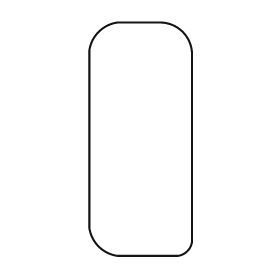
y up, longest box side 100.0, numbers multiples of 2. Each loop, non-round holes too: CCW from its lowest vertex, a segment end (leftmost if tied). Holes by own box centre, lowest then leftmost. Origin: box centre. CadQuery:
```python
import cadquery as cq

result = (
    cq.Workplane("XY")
    .moveTo(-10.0, -50.0)
    .lineTo(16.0, -50.0)
    .threePointArc((20.0, -48.0), (22.0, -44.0))
    .lineTo(22.0, 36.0)
    .threePointArc((18.0, 46.0), (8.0, 50.0))
    .lineTo(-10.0, 50.0)
    .threePointArc((-18.0, 46.0), (-22.0, 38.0))
    .lineTo(-22.0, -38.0)
    .threePointArc((-18.0, -46.0), (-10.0, -50.0))
    .close()
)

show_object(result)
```